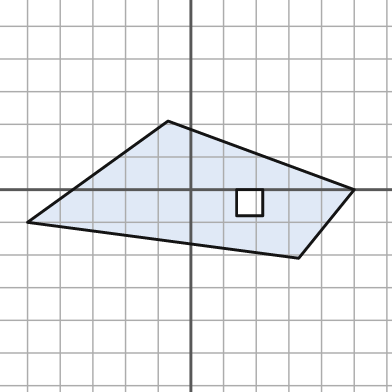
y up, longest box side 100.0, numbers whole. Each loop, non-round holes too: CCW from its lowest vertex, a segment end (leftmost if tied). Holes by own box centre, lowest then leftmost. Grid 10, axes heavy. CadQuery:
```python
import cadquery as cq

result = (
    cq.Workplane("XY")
    .moveTo(33.0, -21.0)
    .lineTo(50.0, 0.0)
    .lineTo(-7.0, 21.0)
    .lineTo(-50.0, -10.0)
    .close()
    .moveTo(14.0, -8.0)
    .lineTo(22.0, -8.0)
    .lineTo(22.0, 0.0)
    .lineTo(14.0, 0.0)
    .close()
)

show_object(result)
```